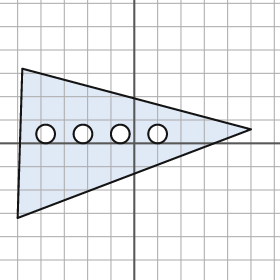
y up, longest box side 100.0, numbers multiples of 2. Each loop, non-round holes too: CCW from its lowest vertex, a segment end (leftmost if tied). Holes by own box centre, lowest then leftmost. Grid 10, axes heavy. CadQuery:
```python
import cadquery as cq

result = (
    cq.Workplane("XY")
    .moveTo(-50.0, -32.0)
    .lineTo(50.0, 6.0)
    .lineTo(-48.0, 32.0)
    .close()
    .moveTo(-38.0, 4.0)
    .circle(4.0)
    .moveTo(-22.0, 4.0)
    .circle(4.0)
    .moveTo(-6.0, 4.0)
    .circle(4.0)
    .moveTo(10.0, 4.0)
    .circle(4.0)
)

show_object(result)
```